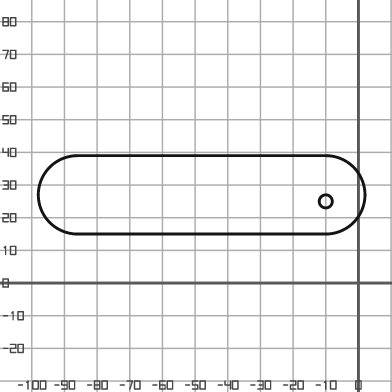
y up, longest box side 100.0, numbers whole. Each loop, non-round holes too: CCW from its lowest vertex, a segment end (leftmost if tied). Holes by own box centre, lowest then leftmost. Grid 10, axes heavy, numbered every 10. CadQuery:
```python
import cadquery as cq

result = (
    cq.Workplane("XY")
    .moveTo(-86.0, 15.0)
    .lineTo(-10.0, 15.0)
    .threePointArc((2.0, 27.0), (-10.0, 39.0))
    .lineTo(-86.0, 39.0)
    .threePointArc((-98.0, 27.0), (-86.0, 15.0))
    .close()
    .moveTo(-10.0, 25.0)
    .circle(2.0)
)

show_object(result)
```